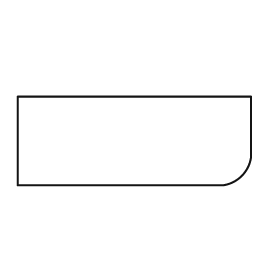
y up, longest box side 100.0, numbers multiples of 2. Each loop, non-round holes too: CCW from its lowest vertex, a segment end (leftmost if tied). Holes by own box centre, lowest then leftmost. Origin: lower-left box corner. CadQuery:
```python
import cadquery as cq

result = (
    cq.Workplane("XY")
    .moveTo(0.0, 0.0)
    .lineTo(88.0, 0.0)
    .threePointArc((96.0, 4.0), (100.0, 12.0))
    .lineTo(100.0, 38.0)
    .lineTo(0.0, 38.0)
    .close()
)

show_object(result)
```